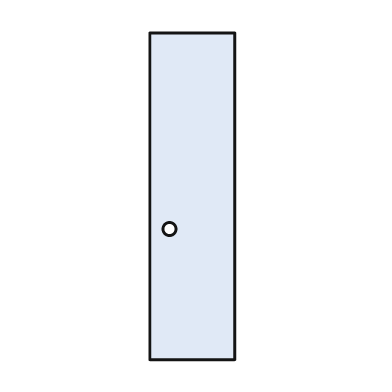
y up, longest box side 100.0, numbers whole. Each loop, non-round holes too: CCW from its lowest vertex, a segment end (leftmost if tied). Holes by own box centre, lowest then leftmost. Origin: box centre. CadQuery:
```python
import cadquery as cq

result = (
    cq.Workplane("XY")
    .moveTo(-13.0, -50.0)
    .lineTo(13.0, -50.0)
    .lineTo(13.0, 50.0)
    .lineTo(-13.0, 50.0)
    .close()
    .moveTo(-7.0, -10.0)
    .circle(2.0)
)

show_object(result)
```